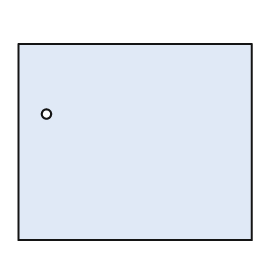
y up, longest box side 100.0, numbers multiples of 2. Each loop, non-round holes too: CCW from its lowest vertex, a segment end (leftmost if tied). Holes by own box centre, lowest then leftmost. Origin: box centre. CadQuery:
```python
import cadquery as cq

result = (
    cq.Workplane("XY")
    .moveTo(-50.0, -42.0)
    .lineTo(50.0, -42.0)
    .lineTo(50.0, 42.0)
    .lineTo(-50.0, 42.0)
    .close()
    .moveTo(-38.0, 12.0)
    .circle(2.0)
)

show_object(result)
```